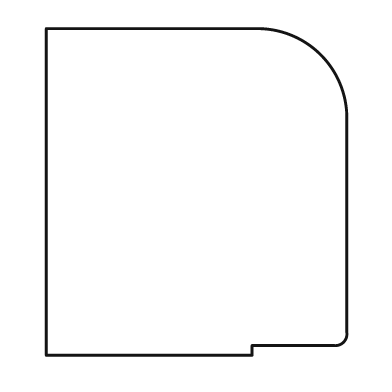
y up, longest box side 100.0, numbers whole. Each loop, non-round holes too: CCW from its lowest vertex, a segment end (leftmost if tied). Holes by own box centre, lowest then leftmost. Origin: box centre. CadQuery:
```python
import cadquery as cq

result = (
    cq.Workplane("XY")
    .moveTo(-46.0, -50.0)
    .lineTo(17.0, -50.0)
    .lineTo(17.0, -47.0)
    .lineTo(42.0, -47.0)
    .threePointArc((45.0, -46.0), (46.0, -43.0))
    .lineTo(46.0, 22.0)
    .threePointArc((38.0, 42.0), (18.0, 50.0))
    .lineTo(-46.0, 50.0)
    .close()
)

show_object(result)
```